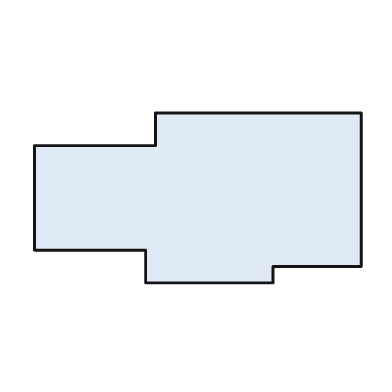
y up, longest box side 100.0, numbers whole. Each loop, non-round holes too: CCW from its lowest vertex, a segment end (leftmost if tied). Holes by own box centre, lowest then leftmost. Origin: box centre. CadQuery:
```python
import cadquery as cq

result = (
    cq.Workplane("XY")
    .moveTo(-16.0, -26.0)
    .lineTo(23.0, -26.0)
    .lineTo(23.0, -21.0)
    .lineTo(50.0, -21.0)
    .lineTo(50.0, 26.0)
    .lineTo(-13.0, 26.0)
    .lineTo(-13.0, 16.0)
    .lineTo(-50.0, 16.0)
    .lineTo(-50.0, -16.0)
    .lineTo(-16.0, -16.0)
    .close()
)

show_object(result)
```